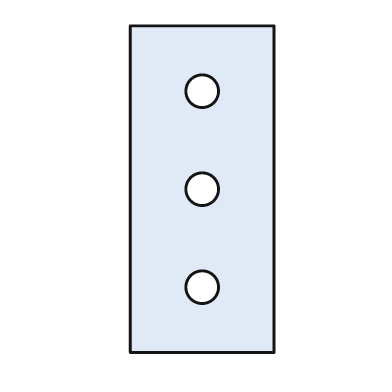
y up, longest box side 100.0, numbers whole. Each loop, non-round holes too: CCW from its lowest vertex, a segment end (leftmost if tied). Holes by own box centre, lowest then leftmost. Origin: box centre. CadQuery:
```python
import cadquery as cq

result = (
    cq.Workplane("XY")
    .moveTo(-22.0, -50.0)
    .lineTo(22.0, -50.0)
    .lineTo(22.0, 50.0)
    .lineTo(-22.0, 50.0)
    .close()
    .moveTo(0.0, -30.0)
    .circle(5.0)
    .moveTo(0.0, 0.0)
    .circle(5.0)
    .moveTo(0.0, 30.0)
    .circle(5.0)
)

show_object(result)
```